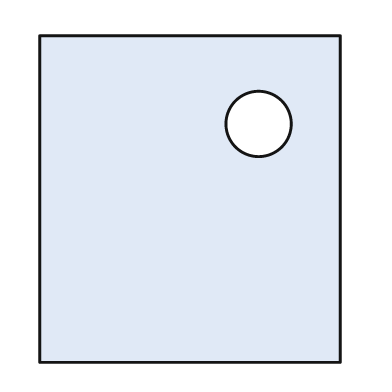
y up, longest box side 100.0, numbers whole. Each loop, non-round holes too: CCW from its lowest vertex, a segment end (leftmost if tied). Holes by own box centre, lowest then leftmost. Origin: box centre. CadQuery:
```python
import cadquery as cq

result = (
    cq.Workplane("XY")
    .moveTo(-46.0, -50.0)
    .lineTo(46.0, -50.0)
    .lineTo(46.0, 50.0)
    .lineTo(-46.0, 50.0)
    .close()
    .moveTo(21.0, 23.0)
    .circle(10.0)
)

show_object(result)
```